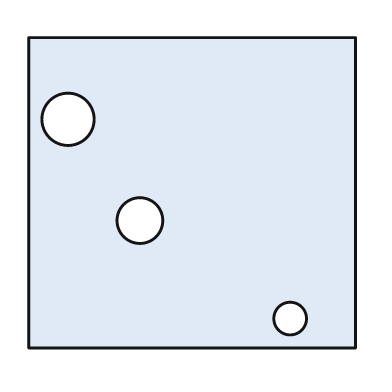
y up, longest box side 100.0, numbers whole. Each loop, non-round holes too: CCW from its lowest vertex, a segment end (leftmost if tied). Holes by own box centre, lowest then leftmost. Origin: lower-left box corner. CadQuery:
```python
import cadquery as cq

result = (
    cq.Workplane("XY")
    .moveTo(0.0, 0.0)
    .lineTo(100.0, 0.0)
    .lineTo(100.0, 95.0)
    .lineTo(0.0, 95.0)
    .close()
    .moveTo(80.0, 9.0)
    .circle(5.0)
    .moveTo(34.0, 39.0)
    .circle(7.0)
    .moveTo(12.0, 70.0)
    .circle(8.0)
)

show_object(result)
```